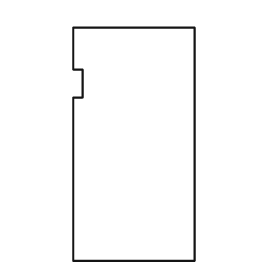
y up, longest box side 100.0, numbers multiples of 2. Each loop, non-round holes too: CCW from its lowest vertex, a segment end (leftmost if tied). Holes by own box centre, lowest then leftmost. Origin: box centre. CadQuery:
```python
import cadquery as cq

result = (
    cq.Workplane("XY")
    .moveTo(-26.0, -50.0)
    .lineTo(26.0, -50.0)
    .lineTo(26.0, 50.0)
    .lineTo(-26.0, 50.0)
    .lineTo(-26.0, 32.0)
    .lineTo(-22.0, 32.0)
    .lineTo(-22.0, 20.0)
    .lineTo(-26.0, 20.0)
    .close()
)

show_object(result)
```